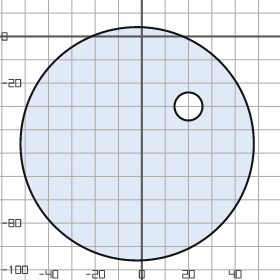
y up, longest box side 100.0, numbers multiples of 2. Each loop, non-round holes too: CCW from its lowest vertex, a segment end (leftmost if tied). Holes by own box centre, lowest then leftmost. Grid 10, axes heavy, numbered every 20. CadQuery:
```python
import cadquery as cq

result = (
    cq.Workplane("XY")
    .moveTo(-2.0, -46.0)
    .circle(50.0)
    .moveTo(20.0, -30.0)
    .circle(6.0)
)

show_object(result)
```